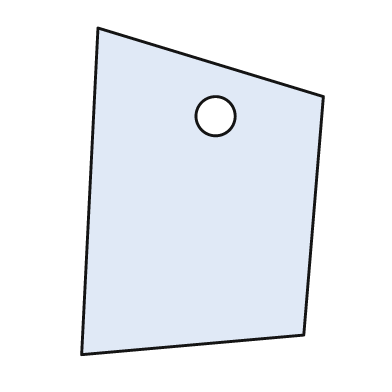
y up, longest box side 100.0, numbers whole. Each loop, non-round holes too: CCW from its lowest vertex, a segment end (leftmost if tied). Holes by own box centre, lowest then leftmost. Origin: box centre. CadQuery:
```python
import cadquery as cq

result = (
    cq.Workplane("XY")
    .moveTo(-37.0, -50.0)
    .lineTo(31.0, -44.0)
    .lineTo(37.0, 29.0)
    .lineTo(-32.0, 50.0)
    .close()
    .moveTo(4.0, 23.0)
    .circle(6.0)
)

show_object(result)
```